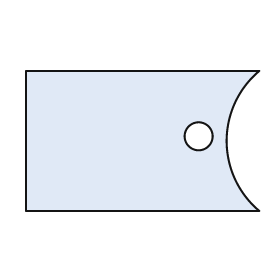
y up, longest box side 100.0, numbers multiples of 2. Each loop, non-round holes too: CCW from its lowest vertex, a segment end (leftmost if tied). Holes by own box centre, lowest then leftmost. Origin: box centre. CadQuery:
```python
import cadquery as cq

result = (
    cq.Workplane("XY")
    .moveTo(-50.0, -30.0)
    .lineTo(50.0, -30.0)
    .threePointArc((36.0, 0.0), (50.0, 30.0))
    .lineTo(-50.0, 30.0)
    .close()
    .moveTo(24.0, 2.0)
    .circle(6.0)
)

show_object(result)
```